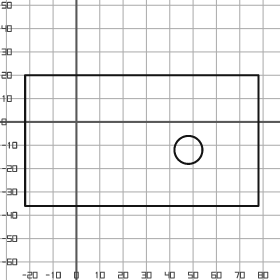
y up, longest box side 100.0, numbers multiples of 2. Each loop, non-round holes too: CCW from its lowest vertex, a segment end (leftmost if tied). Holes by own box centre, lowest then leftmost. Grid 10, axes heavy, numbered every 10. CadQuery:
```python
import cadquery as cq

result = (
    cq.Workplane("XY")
    .moveTo(-22.0, -36.0)
    .lineTo(78.0, -36.0)
    .lineTo(78.0, 20.0)
    .lineTo(-22.0, 20.0)
    .close()
    .moveTo(48.0, -12.0)
    .circle(6.0)
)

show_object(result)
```